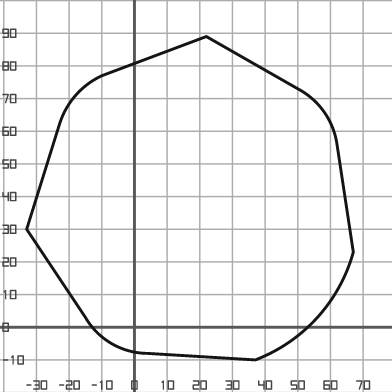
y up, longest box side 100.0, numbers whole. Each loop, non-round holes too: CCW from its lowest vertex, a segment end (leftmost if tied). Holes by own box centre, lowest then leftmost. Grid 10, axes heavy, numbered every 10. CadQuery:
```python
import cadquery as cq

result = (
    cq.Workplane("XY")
    .moveTo(37.0, -10.0)
    .threePointArc((56.0, 3.0), (67.0, 23.0))
    .lineTo(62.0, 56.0)
    .threePointArc((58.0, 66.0), (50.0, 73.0))
    .lineTo(22.0, 89.0)
    .lineTo(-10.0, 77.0)
    .threePointArc((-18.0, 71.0), (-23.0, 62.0))
    .lineTo(-33.0, 30.0)
    .lineTo(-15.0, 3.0)
    .threePointArc((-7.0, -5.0), (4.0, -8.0))
    .close()
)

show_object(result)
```